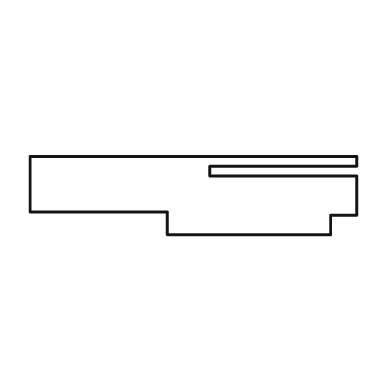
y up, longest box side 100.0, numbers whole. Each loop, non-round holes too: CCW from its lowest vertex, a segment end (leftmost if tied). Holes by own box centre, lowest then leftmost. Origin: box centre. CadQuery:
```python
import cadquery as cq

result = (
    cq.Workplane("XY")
    .moveTo(-8.0, -12.0)
    .lineTo(42.0, -12.0)
    .lineTo(42.0, -6.0)
    .lineTo(50.0, -6.0)
    .lineTo(50.0, 6.0)
    .lineTo(5.0, 6.0)
    .lineTo(5.0, 9.0)
    .lineTo(50.0, 9.0)
    .lineTo(50.0, 12.0)
    .lineTo(-50.0, 12.0)
    .lineTo(-50.0, -5.0)
    .lineTo(-8.0, -5.0)
    .close()
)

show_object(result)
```